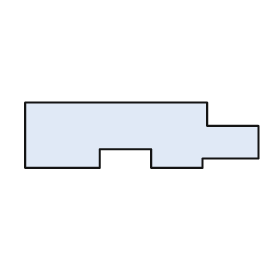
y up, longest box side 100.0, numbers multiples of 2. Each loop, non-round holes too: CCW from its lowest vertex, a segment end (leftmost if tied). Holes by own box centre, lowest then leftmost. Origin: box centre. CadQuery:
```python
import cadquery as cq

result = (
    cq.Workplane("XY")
    .moveTo(-50.0, -14.0)
    .lineTo(-18.0, -14.0)
    .lineTo(-18.0, -6.0)
    .lineTo(4.0, -6.0)
    .lineTo(4.0, -14.0)
    .lineTo(26.0, -14.0)
    .lineTo(26.0, -10.0)
    .lineTo(50.0, -10.0)
    .lineTo(50.0, 4.0)
    .lineTo(28.0, 4.0)
    .lineTo(28.0, 14.0)
    .lineTo(-50.0, 14.0)
    .close()
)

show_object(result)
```